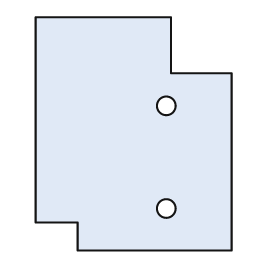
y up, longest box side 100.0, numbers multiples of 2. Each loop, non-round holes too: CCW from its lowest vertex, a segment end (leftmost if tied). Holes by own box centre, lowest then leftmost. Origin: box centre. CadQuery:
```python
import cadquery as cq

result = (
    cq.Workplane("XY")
    .moveTo(-24.0, -50.0)
    .lineTo(42.0, -50.0)
    .lineTo(42.0, 26.0)
    .lineTo(16.0, 26.0)
    .lineTo(16.0, 50.0)
    .lineTo(-42.0, 50.0)
    .lineTo(-42.0, -38.0)
    .lineTo(-24.0, -38.0)
    .close()
    .moveTo(14.0, -32.0)
    .circle(4.0)
    .moveTo(14.0, 12.0)
    .circle(4.0)
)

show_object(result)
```